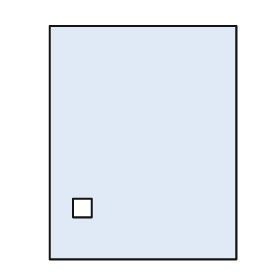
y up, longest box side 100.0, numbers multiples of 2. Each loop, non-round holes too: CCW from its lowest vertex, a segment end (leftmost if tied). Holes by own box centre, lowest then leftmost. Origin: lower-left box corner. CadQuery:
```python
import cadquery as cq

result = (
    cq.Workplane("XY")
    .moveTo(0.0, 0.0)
    .lineTo(80.0, 0.0)
    .lineTo(80.0, 100.0)
    .lineTo(0.0, 100.0)
    .close()
    .moveTo(10.0, 18.0)
    .lineTo(18.0, 18.0)
    .lineTo(18.0, 26.0)
    .lineTo(10.0, 26.0)
    .close()
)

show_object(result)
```